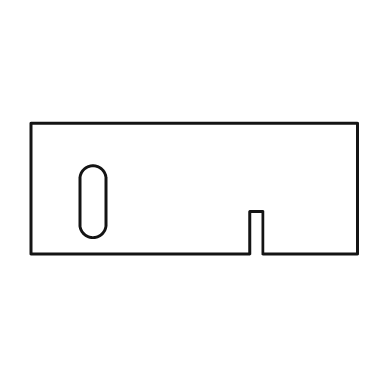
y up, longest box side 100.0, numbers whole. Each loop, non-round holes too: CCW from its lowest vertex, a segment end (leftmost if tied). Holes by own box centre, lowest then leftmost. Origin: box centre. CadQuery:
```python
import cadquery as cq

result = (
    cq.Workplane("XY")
    .moveTo(-50.0, -20.0)
    .lineTo(17.0, -20.0)
    .lineTo(17.0, -7.0)
    .lineTo(21.0, -7.0)
    .lineTo(21.0, -20.0)
    .lineTo(50.0, -20.0)
    .lineTo(50.0, 20.0)
    .lineTo(-50.0, 20.0)
    .close()
    .moveTo(-35.0, -11.0)
    .threePointArc((-31.0, -15.0), (-27.0, -11.0))
    .lineTo(-27.0, 3.0)
    .threePointArc((-31.0, 7.0), (-35.0, 3.0))
    .close()
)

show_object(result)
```